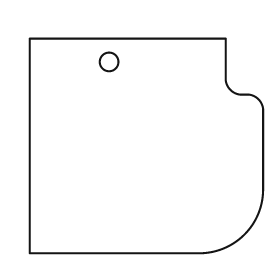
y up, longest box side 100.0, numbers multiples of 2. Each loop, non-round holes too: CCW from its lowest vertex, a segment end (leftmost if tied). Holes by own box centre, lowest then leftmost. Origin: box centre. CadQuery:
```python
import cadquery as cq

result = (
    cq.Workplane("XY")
    .moveTo(-50.0, -46.0)
    .lineTo(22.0, -46.0)
    .threePointArc((42.0, -38.0), (50.0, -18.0))
    .lineTo(50.0, 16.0)
    .threePointArc((48.0, 20.0), (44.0, 22.0))
    .lineTo(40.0, 22.0)
    .threePointArc((36.0, 24.0), (34.0, 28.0))
    .lineTo(34.0, 46.0)
    .lineTo(-50.0, 46.0)
    .close()
    .moveTo(-16.0, 36.0)
    .circle(4.0)
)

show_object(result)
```